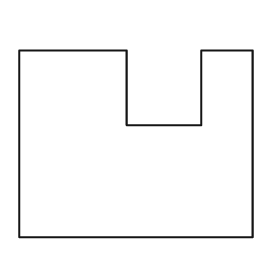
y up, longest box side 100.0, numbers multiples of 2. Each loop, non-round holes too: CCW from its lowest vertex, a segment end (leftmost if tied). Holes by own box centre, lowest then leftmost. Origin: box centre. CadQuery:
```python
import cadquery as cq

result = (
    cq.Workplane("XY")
    .moveTo(-50.0, -40.0)
    .lineTo(50.0, -40.0)
    .lineTo(50.0, 40.0)
    .lineTo(28.0, 40.0)
    .lineTo(28.0, 8.0)
    .lineTo(-4.0, 8.0)
    .lineTo(-4.0, 40.0)
    .lineTo(-50.0, 40.0)
    .close()
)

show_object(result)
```